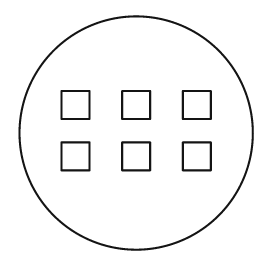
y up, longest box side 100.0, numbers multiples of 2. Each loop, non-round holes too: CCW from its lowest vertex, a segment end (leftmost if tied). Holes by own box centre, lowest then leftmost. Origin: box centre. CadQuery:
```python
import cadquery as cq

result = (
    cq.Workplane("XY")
    .moveTo(0.0, 0.0)
    .circle(50.0)
    .moveTo(-32.0, -16.0)
    .lineTo(-20.0, -16.0)
    .lineTo(-20.0, -4.0)
    .lineTo(-32.0, -4.0)
    .close()
    .moveTo(-6.0, -16.0)
    .lineTo(6.0, -16.0)
    .lineTo(6.0, -4.0)
    .lineTo(-6.0, -4.0)
    .close()
    .moveTo(20.0, -16.0)
    .lineTo(32.0, -16.0)
    .lineTo(32.0, -4.0)
    .lineTo(20.0, -4.0)
    .close()
    .moveTo(-32.0, 6.0)
    .lineTo(-20.0, 6.0)
    .lineTo(-20.0, 18.0)
    .lineTo(-32.0, 18.0)
    .close()
    .moveTo(-6.0, 6.0)
    .lineTo(6.0, 6.0)
    .lineTo(6.0, 18.0)
    .lineTo(-6.0, 18.0)
    .close()
    .moveTo(20.0, 6.0)
    .lineTo(32.0, 6.0)
    .lineTo(32.0, 18.0)
    .lineTo(20.0, 18.0)
    .close()
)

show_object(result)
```